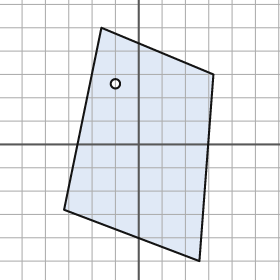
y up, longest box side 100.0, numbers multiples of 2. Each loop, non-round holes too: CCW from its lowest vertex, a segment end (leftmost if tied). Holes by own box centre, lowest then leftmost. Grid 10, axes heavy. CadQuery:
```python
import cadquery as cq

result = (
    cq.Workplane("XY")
    .moveTo(26.0, -50.0)
    .lineTo(32.0, 30.0)
    .lineTo(-16.0, 50.0)
    .lineTo(-32.0, -28.0)
    .close()
    .moveTo(-10.0, 26.0)
    .circle(2.0)
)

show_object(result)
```